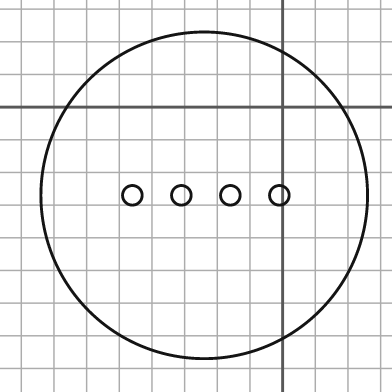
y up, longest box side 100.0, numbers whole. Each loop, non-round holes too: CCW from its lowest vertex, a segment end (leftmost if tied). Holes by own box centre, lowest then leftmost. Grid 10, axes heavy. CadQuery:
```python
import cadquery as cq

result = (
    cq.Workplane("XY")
    .moveTo(-24.0, -27.0)
    .circle(50.0)
    .moveTo(-46.0, -27.0)
    .circle(3.0)
    .moveTo(-31.0, -27.0)
    .circle(3.0)
    .moveTo(-16.0, -27.0)
    .circle(3.0)
    .moveTo(-1.0, -27.0)
    .circle(3.0)
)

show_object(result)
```